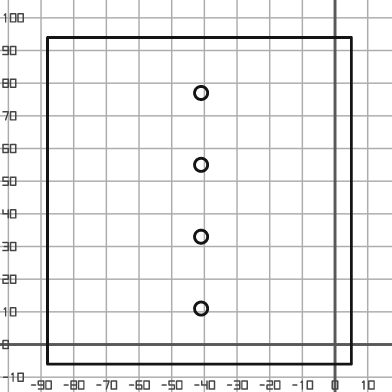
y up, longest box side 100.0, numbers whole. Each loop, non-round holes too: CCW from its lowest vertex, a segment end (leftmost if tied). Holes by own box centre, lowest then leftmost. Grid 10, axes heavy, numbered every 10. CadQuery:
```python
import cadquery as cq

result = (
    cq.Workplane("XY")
    .moveTo(-88.0, -6.0)
    .lineTo(5.0, -6.0)
    .lineTo(5.0, 94.0)
    .lineTo(-88.0, 94.0)
    .close()
    .moveTo(-41.0, 11.0)
    .circle(2.0)
    .moveTo(-41.0, 33.0)
    .circle(2.0)
    .moveTo(-41.0, 55.0)
    .circle(2.0)
    .moveTo(-41.0, 77.0)
    .circle(2.0)
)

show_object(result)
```